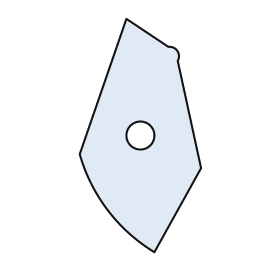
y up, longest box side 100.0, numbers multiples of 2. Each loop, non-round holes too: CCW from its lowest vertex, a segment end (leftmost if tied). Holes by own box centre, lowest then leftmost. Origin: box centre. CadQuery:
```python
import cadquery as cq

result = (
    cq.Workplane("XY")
    .moveTo(6.0, -50.0)
    .lineTo(26.0, -14.0)
    .lineTo(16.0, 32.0)
    .threePointArc((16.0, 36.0), (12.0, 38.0))
    .lineTo(-6.0, 50.0)
    .lineTo(-26.0, -8.0)
    .threePointArc((-14.0, -32.0), (6.0, -50.0))
    .close()
    .moveTo(0.0, 0.0)
    .circle(6.0)
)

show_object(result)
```